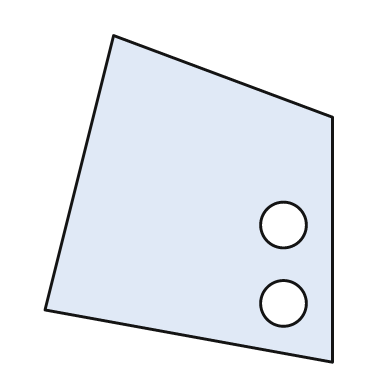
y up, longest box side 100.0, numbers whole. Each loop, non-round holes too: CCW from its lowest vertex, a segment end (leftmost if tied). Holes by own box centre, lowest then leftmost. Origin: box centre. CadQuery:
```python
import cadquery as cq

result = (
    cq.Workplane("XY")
    .moveTo(44.0, -50.0)
    .lineTo(44.0, 25.0)
    .lineTo(-23.0, 50.0)
    .lineTo(-44.0, -34.0)
    .close()
    .moveTo(29.0, -32.0)
    .circle(7.0)
    .moveTo(29.0, -8.0)
    .circle(7.0)
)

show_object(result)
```